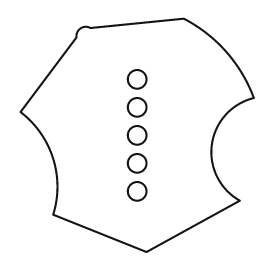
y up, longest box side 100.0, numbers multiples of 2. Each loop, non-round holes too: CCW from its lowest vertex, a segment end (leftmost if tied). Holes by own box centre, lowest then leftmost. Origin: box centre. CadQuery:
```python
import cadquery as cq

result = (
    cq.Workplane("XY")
    .moveTo(4.0, -50.0)
    .lineTo(44.0, -28.0)
    .threePointArc((32.0, -4.0), (50.0, 16.0))
    .threePointArc((38.0, 36.0), (20.0, 50.0))
    .lineTo(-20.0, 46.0)
    .threePointArc((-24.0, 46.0), (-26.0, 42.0))
    .lineTo(-50.0, 10.0)
    .threePointArc((-36.0, -10.0), (-36.0, -34.0))
    .close()
    .moveTo(0.0, -24.0)
    .circle(4.0)
    .moveTo(0.0, -12.0)
    .circle(4.0)
    .moveTo(0.0, 0.0)
    .circle(4.0)
    .moveTo(0.0, 12.0)
    .circle(4.0)
    .moveTo(0.0, 24.0)
    .circle(4.0)
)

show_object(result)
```